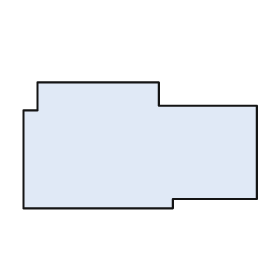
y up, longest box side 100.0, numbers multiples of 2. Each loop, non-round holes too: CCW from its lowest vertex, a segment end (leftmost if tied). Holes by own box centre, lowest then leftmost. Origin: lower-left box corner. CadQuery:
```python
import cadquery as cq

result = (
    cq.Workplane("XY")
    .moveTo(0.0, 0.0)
    .lineTo(64.0, 0.0)
    .lineTo(64.0, 4.0)
    .lineTo(100.0, 4.0)
    .lineTo(100.0, 44.0)
    .lineTo(58.0, 44.0)
    .lineTo(58.0, 54.0)
    .lineTo(6.0, 54.0)
    .lineTo(6.0, 42.0)
    .lineTo(0.0, 42.0)
    .close()
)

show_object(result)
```